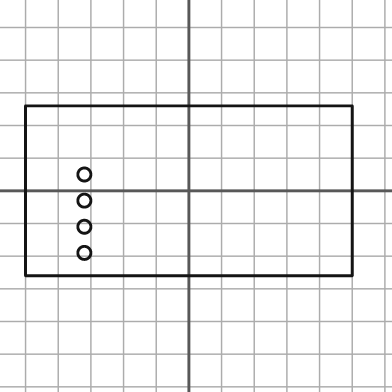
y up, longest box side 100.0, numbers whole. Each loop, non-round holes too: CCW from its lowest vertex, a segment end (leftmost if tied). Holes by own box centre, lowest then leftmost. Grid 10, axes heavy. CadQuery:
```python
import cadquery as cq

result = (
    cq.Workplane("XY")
    .moveTo(-50.0, -26.0)
    .lineTo(50.0, -26.0)
    .lineTo(50.0, 26.0)
    .lineTo(-50.0, 26.0)
    .close()
    .moveTo(-32.0, -19.0)
    .circle(2.0)
    .moveTo(-32.0, -11.0)
    .circle(2.0)
    .moveTo(-32.0, -3.0)
    .circle(2.0)
    .moveTo(-32.0, 5.0)
    .circle(2.0)
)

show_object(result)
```